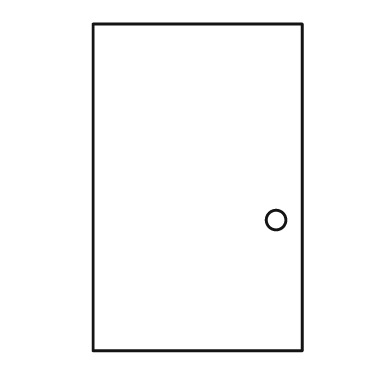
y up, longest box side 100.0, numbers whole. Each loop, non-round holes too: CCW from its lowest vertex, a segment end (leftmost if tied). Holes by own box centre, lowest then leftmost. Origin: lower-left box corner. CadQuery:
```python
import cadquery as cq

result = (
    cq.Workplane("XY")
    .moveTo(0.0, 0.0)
    .lineTo(64.0, 0.0)
    .lineTo(64.0, 100.0)
    .lineTo(0.0, 100.0)
    .close()
    .moveTo(56.0, 40.0)
    .circle(3.0)
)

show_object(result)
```